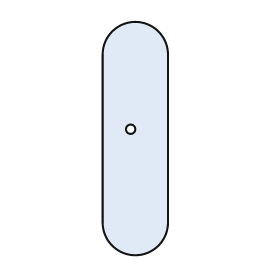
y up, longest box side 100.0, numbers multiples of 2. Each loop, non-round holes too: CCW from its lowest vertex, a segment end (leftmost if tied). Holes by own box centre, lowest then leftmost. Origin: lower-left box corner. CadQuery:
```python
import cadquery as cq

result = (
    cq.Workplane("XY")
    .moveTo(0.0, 14.0)
    .threePointArc((14.0, 0.0), (28.0, 14.0))
    .lineTo(28.0, 86.0)
    .threePointArc((14.0, 100.0), (0.0, 86.0))
    .close()
    .moveTo(12.0, 54.0)
    .circle(2.0)
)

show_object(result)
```